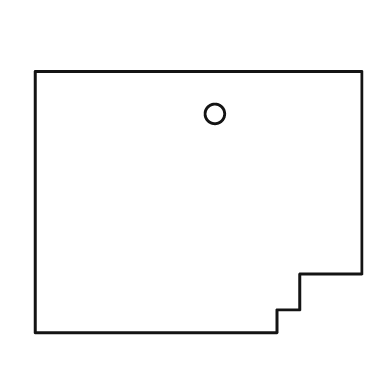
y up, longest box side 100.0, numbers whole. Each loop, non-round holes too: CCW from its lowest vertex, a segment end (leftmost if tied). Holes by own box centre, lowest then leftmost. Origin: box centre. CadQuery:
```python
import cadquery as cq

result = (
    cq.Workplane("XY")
    .moveTo(-50.0, -40.0)
    .lineTo(24.0, -40.0)
    .lineTo(24.0, -33.0)
    .lineTo(31.0, -33.0)
    .lineTo(31.0, -22.0)
    .lineTo(50.0, -22.0)
    .lineTo(50.0, 40.0)
    .lineTo(-50.0, 40.0)
    .close()
    .moveTo(5.0, 27.0)
    .circle(3.0)
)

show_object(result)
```